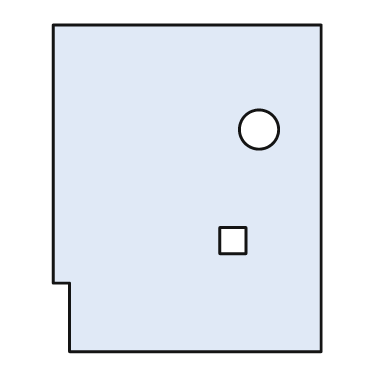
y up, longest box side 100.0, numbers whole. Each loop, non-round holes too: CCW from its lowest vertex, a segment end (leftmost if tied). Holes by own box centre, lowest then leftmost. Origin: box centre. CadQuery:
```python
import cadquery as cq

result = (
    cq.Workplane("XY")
    .moveTo(-36.0, -50.0)
    .lineTo(41.0, -50.0)
    .lineTo(41.0, 50.0)
    .lineTo(-41.0, 50.0)
    .lineTo(-41.0, -29.0)
    .lineTo(-36.0, -29.0)
    .close()
    .moveTo(10.0, -20.0)
    .lineTo(18.0, -20.0)
    .lineTo(18.0, -12.0)
    .lineTo(10.0, -12.0)
    .close()
    .moveTo(22.0, 18.0)
    .circle(6.0)
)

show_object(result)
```